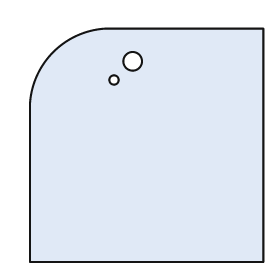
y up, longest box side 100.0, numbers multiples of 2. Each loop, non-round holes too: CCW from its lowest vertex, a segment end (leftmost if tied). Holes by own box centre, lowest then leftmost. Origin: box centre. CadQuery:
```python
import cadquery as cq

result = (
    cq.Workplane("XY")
    .moveTo(-50.0, -50.0)
    .lineTo(50.0, -50.0)
    .lineTo(50.0, 50.0)
    .lineTo(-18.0, 50.0)
    .threePointArc((-40.0, 40.0), (-50.0, 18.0))
    .close()
    .moveTo(-14.0, 28.0)
    .circle(2.0)
    .moveTo(-6.0, 36.0)
    .circle(4.0)
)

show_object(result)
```